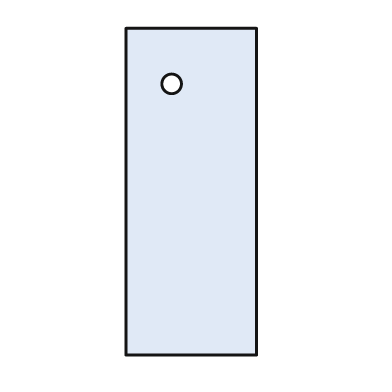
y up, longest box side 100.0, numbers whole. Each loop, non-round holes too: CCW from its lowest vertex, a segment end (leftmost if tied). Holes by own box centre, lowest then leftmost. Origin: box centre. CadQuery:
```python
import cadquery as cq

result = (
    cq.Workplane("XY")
    .moveTo(-20.0, -50.0)
    .lineTo(20.0, -50.0)
    .lineTo(20.0, 50.0)
    .lineTo(-20.0, 50.0)
    .close()
    .moveTo(-6.0, 33.0)
    .circle(3.0)
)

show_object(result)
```